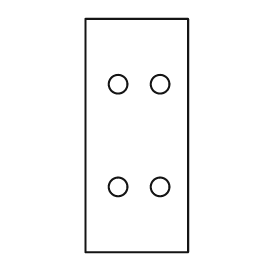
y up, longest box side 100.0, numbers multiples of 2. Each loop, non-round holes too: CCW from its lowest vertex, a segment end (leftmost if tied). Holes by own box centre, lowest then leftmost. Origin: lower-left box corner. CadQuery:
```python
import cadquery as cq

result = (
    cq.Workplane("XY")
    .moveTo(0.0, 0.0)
    .lineTo(44.0, 0.0)
    .lineTo(44.0, 100.0)
    .lineTo(0.0, 100.0)
    .close()
    .moveTo(14.0, 28.0)
    .circle(4.0)
    .moveTo(32.0, 28.0)
    .circle(4.0)
    .moveTo(14.0, 72.0)
    .circle(4.0)
    .moveTo(32.0, 72.0)
    .circle(4.0)
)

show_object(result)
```